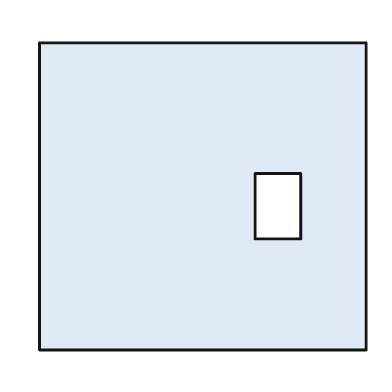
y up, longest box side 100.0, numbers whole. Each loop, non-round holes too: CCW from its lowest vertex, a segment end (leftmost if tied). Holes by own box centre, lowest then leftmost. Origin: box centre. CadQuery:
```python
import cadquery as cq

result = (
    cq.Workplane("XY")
    .moveTo(-50.0, -47.0)
    .lineTo(50.0, -47.0)
    .lineTo(50.0, 47.0)
    .lineTo(-50.0, 47.0)
    .close()
    .moveTo(16.0, -13.0)
    .lineTo(30.0, -13.0)
    .lineTo(30.0, 7.0)
    .lineTo(16.0, 7.0)
    .close()
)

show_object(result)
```